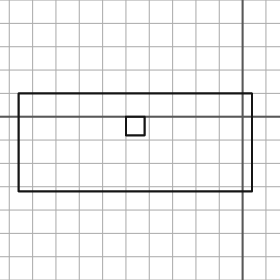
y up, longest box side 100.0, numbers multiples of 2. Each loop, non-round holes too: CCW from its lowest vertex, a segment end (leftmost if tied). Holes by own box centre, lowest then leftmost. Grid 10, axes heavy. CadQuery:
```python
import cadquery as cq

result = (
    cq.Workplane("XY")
    .moveTo(-96.0, -32.0)
    .lineTo(4.0, -32.0)
    .lineTo(4.0, 10.0)
    .lineTo(-96.0, 10.0)
    .close()
    .moveTo(-50.0, -8.0)
    .lineTo(-42.0, -8.0)
    .lineTo(-42.0, 0.0)
    .lineTo(-50.0, 0.0)
    .close()
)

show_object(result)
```